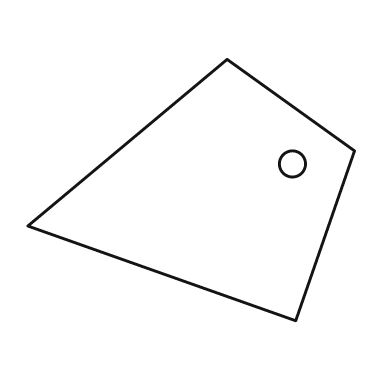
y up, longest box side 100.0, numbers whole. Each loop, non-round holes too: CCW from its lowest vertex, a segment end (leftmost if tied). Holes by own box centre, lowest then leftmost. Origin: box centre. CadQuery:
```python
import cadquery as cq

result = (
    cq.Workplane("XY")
    .moveTo(32.0, -40.0)
    .lineTo(50.0, 12.0)
    .lineTo(11.0, 40.0)
    .lineTo(-50.0, -11.0)
    .close()
    .moveTo(31.0, 8.0)
    .circle(4.0)
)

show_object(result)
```